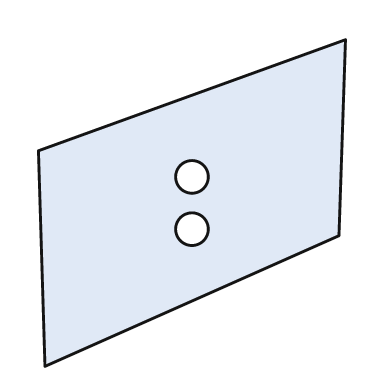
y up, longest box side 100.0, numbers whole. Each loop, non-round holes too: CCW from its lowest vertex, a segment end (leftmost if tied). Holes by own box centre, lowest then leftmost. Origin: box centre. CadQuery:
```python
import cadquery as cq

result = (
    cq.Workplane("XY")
    .moveTo(-45.0, -50.0)
    .lineTo(45.0, -10.0)
    .lineTo(47.0, 50.0)
    .lineTo(-47.0, 16.0)
    .close()
    .moveTo(0.0, -8.0)
    .circle(5.0)
    .moveTo(0.0, 8.0)
    .circle(5.0)
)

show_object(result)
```